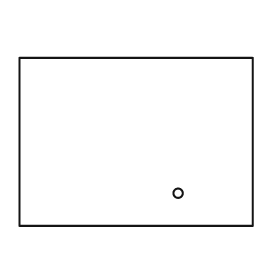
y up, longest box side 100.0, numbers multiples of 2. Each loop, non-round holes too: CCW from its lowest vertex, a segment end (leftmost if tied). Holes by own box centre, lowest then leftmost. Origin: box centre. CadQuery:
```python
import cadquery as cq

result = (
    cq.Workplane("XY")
    .moveTo(-50.0, -36.0)
    .lineTo(50.0, -36.0)
    .lineTo(50.0, 36.0)
    .lineTo(-50.0, 36.0)
    .close()
    .moveTo(18.0, -22.0)
    .circle(2.0)
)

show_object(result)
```